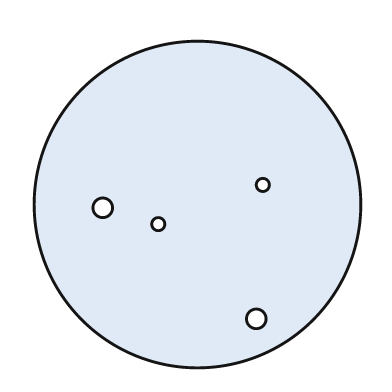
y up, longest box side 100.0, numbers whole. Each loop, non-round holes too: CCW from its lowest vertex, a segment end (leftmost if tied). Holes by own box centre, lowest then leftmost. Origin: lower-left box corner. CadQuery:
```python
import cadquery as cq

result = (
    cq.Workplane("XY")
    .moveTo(50.0, 50.0)
    .circle(50.0)
    .moveTo(68.0, 15.0)
    .circle(3.0)
    .moveTo(38.0, 44.0)
    .circle(2.0)
    .moveTo(21.0, 49.0)
    .circle(3.0)
    .moveTo(70.0, 56.0)
    .circle(2.0)
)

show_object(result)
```